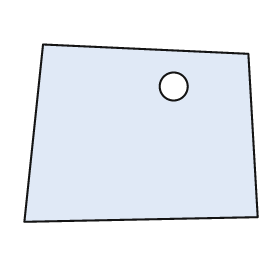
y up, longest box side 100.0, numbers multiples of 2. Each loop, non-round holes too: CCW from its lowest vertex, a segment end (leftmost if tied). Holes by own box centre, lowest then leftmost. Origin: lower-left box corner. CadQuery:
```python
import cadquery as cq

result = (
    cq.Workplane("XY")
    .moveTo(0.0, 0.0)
    .lineTo(100.0, 2.0)
    .lineTo(96.0, 72.0)
    .lineTo(8.0, 76.0)
    .close()
    .moveTo(64.0, 58.0)
    .circle(6.0)
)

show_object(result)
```